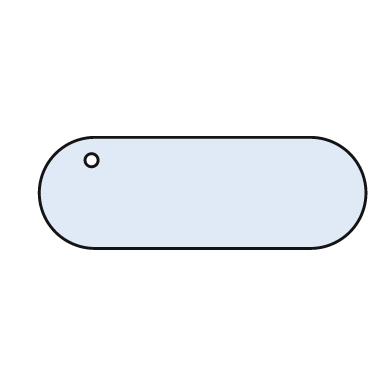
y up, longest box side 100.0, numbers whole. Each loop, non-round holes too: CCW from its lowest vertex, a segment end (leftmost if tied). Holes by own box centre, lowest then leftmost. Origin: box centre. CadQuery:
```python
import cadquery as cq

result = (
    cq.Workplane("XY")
    .moveTo(-33.0, -17.0)
    .lineTo(33.0, -17.0)
    .threePointArc((50.0, 0.0), (33.0, 17.0))
    .lineTo(-33.0, 17.0)
    .threePointArc((-50.0, 0.0), (-33.0, -17.0))
    .close()
    .moveTo(-34.0, 10.0)
    .circle(2.0)
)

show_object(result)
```